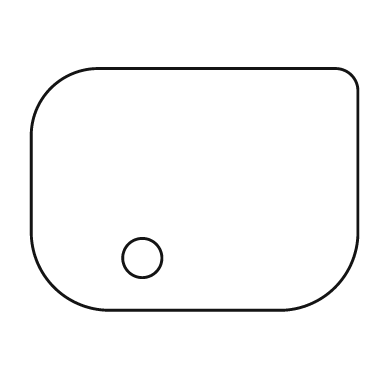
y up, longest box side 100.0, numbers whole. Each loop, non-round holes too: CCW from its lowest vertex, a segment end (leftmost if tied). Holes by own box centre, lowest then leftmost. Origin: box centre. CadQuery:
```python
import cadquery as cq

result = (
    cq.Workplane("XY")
    .moveTo(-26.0, -37.0)
    .lineTo(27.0, -37.0)
    .threePointArc((43.0, -30.0), (50.0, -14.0))
    .lineTo(50.0, 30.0)
    .threePointArc((48.0, 35.0), (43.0, 37.0))
    .lineTo(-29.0, 37.0)
    .threePointArc((-44.0, 31.0), (-50.0, 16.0))
    .lineTo(-50.0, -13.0)
    .threePointArc((-43.0, -30.0), (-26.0, -37.0))
    .close()
    .moveTo(-16.0, -21.0)
    .circle(6.0)
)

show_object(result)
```